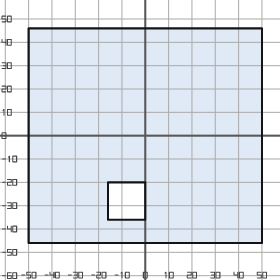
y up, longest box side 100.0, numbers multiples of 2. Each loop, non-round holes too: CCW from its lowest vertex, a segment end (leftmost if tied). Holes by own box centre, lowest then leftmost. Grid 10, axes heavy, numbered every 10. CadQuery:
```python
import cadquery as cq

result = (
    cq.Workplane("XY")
    .moveTo(-50.0, -46.0)
    .lineTo(50.0, -46.0)
    .lineTo(50.0, 46.0)
    .lineTo(-50.0, 46.0)
    .close()
    .moveTo(-16.0, -36.0)
    .lineTo(0.0, -36.0)
    .lineTo(0.0, -20.0)
    .lineTo(-16.0, -20.0)
    .close()
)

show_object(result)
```